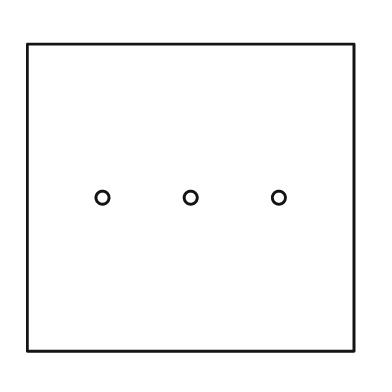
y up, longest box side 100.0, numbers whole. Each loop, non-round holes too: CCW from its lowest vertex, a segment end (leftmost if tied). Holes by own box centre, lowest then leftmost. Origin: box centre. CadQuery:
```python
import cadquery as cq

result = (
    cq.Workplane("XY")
    .moveTo(-50.0, -47.0)
    .lineTo(50.0, -47.0)
    .lineTo(50.0, 47.0)
    .lineTo(-50.0, 47.0)
    .close()
    .moveTo(-27.0, 0.0)
    .circle(2.0)
    .moveTo(0.0, 0.0)
    .circle(2.0)
    .moveTo(27.0, 0.0)
    .circle(2.0)
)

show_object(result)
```